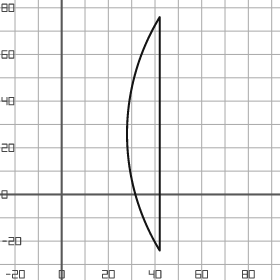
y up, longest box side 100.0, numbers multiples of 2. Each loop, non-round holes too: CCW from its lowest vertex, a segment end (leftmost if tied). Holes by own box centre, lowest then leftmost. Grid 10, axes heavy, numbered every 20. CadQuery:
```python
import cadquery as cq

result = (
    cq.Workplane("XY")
    .moveTo(42.0, -24.0)
    .lineTo(42.0, 76.0)
    .threePointArc((28.0, 26.0), (42.0, -24.0))
    .close()
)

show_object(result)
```